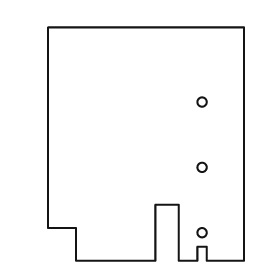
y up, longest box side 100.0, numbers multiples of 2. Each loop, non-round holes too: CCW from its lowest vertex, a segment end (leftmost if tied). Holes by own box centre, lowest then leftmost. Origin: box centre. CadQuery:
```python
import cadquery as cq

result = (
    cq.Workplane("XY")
    .moveTo(-30.0, -50.0)
    .lineTo(4.0, -50.0)
    .lineTo(4.0, -26.0)
    .lineTo(14.0, -26.0)
    .lineTo(14.0, -50.0)
    .lineTo(22.0, -50.0)
    .lineTo(22.0, -44.0)
    .lineTo(26.0, -44.0)
    .lineTo(26.0, -50.0)
    .lineTo(42.0, -50.0)
    .lineTo(42.0, 50.0)
    .lineTo(-42.0, 50.0)
    .lineTo(-42.0, -36.0)
    .lineTo(-30.0, -36.0)
    .close()
    .moveTo(24.0, -38.0)
    .circle(2.0)
    .moveTo(24.0, -10.0)
    .circle(2.0)
    .moveTo(24.0, 18.0)
    .circle(2.0)
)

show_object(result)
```